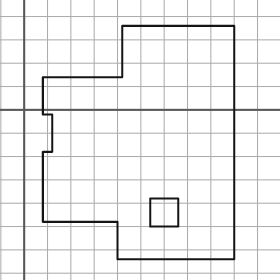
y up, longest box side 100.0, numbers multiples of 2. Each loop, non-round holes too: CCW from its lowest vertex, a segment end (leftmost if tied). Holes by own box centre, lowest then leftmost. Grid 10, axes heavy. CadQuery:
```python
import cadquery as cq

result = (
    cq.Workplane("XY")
    .moveTo(40.0, -64.0)
    .lineTo(90.0, -64.0)
    .lineTo(90.0, 36.0)
    .lineTo(42.0, 36.0)
    .lineTo(42.0, 14.0)
    .lineTo(8.0, 14.0)
    .lineTo(8.0, -2.0)
    .lineTo(12.0, -2.0)
    .lineTo(12.0, -18.0)
    .lineTo(8.0, -18.0)
    .lineTo(8.0, -48.0)
    .lineTo(40.0, -48.0)
    .close()
    .moveTo(54.0, -50.0)
    .lineTo(66.0, -50.0)
    .lineTo(66.0, -38.0)
    .lineTo(54.0, -38.0)
    .close()
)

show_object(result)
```